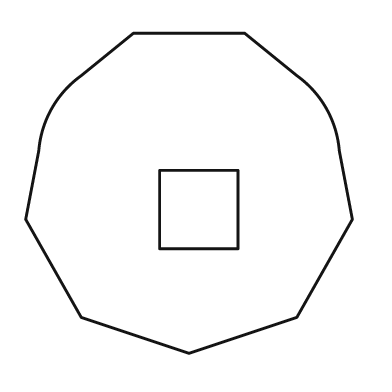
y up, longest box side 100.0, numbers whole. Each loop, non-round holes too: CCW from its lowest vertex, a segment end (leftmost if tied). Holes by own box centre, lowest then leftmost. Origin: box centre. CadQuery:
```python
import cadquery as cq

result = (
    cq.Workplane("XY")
    .moveTo(0.0, -49.0)
    .lineTo(33.0, -38.0)
    .lineTo(50.0, -8.0)
    .lineTo(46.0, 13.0)
    .threePointArc((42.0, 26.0), (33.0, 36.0))
    .lineTo(17.0, 49.0)
    .lineTo(-17.0, 49.0)
    .lineTo(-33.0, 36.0)
    .threePointArc((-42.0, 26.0), (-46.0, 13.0))
    .lineTo(-50.0, -8.0)
    .lineTo(-33.0, -38.0)
    .close()
    .moveTo(-9.0, -17.0)
    .lineTo(15.0, -17.0)
    .lineTo(15.0, 7.0)
    .lineTo(-9.0, 7.0)
    .close()
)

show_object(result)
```